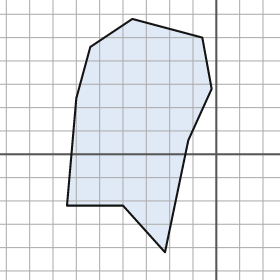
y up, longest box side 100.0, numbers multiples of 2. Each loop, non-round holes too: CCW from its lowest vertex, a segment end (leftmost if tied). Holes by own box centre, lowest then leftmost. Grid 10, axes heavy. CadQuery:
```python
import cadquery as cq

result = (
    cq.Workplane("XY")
    .moveTo(-22.0, -42.0)
    .lineTo(-12.0, 6.0)
    .lineTo(-2.0, 28.0)
    .lineTo(-6.0, 50.0)
    .lineTo(-36.0, 58.0)
    .lineTo(-54.0, 46.0)
    .lineTo(-60.0, 24.0)
    .lineTo(-64.0, -22.0)
    .lineTo(-40.0, -22.0)
    .close()
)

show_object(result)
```